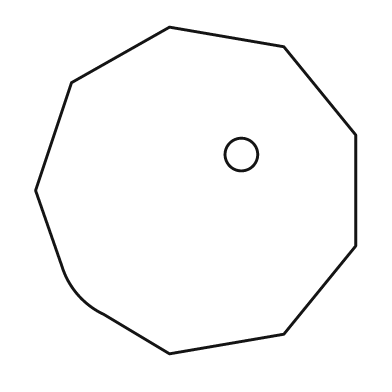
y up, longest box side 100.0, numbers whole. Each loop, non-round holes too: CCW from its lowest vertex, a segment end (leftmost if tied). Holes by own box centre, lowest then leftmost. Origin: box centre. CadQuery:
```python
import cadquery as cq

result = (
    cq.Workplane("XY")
    .moveTo(-8.0, -50.0)
    .lineTo(27.0, -44.0)
    .lineTo(49.0, -17.0)
    .lineTo(49.0, 17.0)
    .lineTo(27.0, 44.0)
    .lineTo(-8.0, 50.0)
    .lineTo(-38.0, 33.0)
    .lineTo(-49.0, 0.0)
    .lineTo(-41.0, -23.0)
    .threePointArc((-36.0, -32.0), (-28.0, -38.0))
    .close()
    .moveTo(14.0, 11.0)
    .circle(5.0)
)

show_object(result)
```